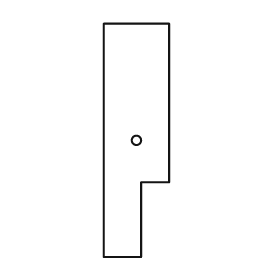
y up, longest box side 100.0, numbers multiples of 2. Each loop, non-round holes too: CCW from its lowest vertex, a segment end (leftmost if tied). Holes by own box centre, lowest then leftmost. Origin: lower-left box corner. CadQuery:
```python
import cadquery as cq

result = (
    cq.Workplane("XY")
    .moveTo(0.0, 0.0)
    .lineTo(16.0, 0.0)
    .lineTo(16.0, 32.0)
    .lineTo(28.0, 32.0)
    .lineTo(28.0, 100.0)
    .lineTo(0.0, 100.0)
    .close()
    .moveTo(14.0, 50.0)
    .circle(2.0)
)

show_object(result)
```